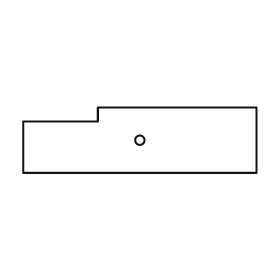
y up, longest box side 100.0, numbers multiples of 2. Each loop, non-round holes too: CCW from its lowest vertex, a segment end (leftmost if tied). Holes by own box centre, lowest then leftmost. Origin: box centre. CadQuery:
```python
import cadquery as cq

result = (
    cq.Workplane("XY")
    .moveTo(-50.0, -14.0)
    .lineTo(50.0, -14.0)
    .lineTo(50.0, 14.0)
    .lineTo(-18.0, 14.0)
    .lineTo(-18.0, 8.0)
    .lineTo(-50.0, 8.0)
    .close()
    .moveTo(0.0, 0.0)
    .circle(2.0)
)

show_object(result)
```